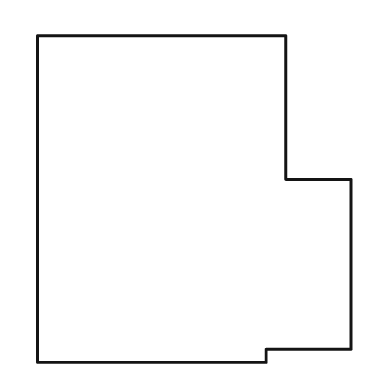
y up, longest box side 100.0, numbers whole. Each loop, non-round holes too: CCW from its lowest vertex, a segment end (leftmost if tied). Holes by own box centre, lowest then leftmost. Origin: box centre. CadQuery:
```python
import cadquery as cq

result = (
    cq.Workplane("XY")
    .moveTo(-48.0, -50.0)
    .lineTo(22.0, -50.0)
    .lineTo(22.0, -46.0)
    .lineTo(48.0, -46.0)
    .lineTo(48.0, 6.0)
    .lineTo(28.0, 6.0)
    .lineTo(28.0, 50.0)
    .lineTo(-48.0, 50.0)
    .close()
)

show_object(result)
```